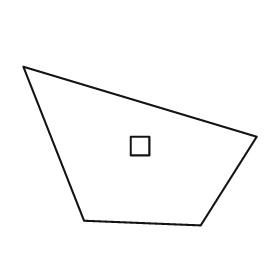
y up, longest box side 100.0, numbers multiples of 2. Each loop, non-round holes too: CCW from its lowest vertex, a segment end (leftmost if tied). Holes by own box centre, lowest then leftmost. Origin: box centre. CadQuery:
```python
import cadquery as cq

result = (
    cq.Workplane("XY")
    .moveTo(26.0, -34.0)
    .lineTo(50.0, 4.0)
    .lineTo(-50.0, 34.0)
    .lineTo(-24.0, -32.0)
    .close()
    .moveTo(-4.0, -4.0)
    .lineTo(4.0, -4.0)
    .lineTo(4.0, 4.0)
    .lineTo(-4.0, 4.0)
    .close()
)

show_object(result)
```